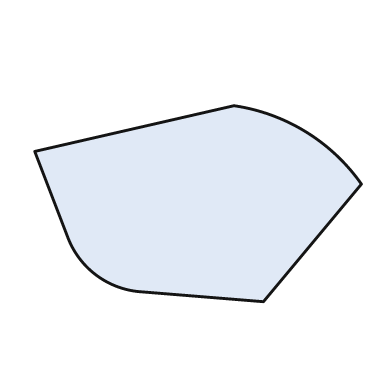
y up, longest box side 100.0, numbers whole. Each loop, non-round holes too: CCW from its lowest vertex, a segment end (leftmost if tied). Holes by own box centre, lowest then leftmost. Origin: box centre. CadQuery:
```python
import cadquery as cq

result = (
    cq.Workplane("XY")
    .moveTo(20.0, -30.0)
    .lineTo(50.0, 6.0)
    .threePointArc((33.0, 22.0), (11.0, 30.0))
    .lineTo(-50.0, 16.0)
    .lineTo(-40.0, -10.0)
    .threePointArc((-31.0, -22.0), (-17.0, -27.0))
    .close()
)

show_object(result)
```